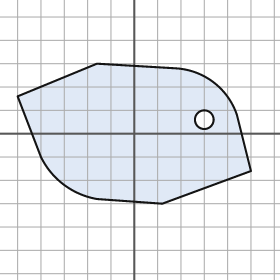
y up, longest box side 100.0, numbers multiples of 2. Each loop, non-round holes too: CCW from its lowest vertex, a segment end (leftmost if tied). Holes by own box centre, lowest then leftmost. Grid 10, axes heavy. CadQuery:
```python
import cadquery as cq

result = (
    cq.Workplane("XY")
    .moveTo(12.0, -30.0)
    .lineTo(50.0, -16.0)
    .lineTo(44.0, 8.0)
    .threePointArc((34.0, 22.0), (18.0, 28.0))
    .lineTo(-16.0, 30.0)
    .lineTo(-50.0, 16.0)
    .lineTo(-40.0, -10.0)
    .threePointArc((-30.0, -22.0), (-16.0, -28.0))
    .close()
    .moveTo(30.0, 6.0)
    .circle(4.0)
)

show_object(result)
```